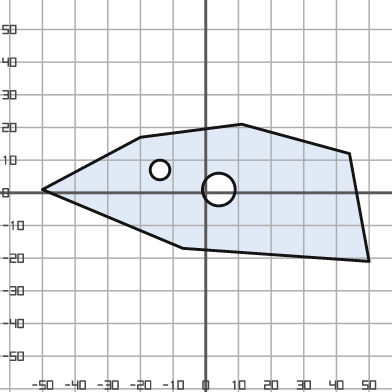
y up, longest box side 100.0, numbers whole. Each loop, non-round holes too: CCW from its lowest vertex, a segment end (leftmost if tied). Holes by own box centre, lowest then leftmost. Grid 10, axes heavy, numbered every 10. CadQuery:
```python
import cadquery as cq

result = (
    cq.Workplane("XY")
    .moveTo(50.0, -21.0)
    .lineTo(44.0, 12.0)
    .lineTo(11.0, 21.0)
    .lineTo(-20.0, 17.0)
    .lineTo(-50.0, 1.0)
    .lineTo(-7.0, -17.0)
    .close()
    .moveTo(4.0, 1.0)
    .circle(5.0)
    .moveTo(-14.0, 7.0)
    .circle(3.0)
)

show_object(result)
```